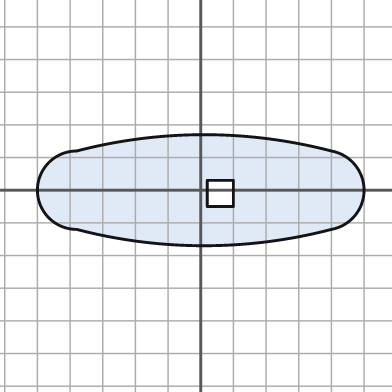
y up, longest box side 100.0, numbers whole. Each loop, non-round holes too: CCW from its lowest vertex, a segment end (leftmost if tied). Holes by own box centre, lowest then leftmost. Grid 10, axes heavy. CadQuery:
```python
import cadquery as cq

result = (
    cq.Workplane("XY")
    .moveTo(-38.0, -12.0)
    .threePointArc((1.0, -17.0), (40.0, -12.0))
    .threePointArc((50.0, 0.0), (40.0, 12.0))
    .threePointArc((1.0, 17.0), (-38.0, 12.0))
    .threePointArc((-50.0, 0.0), (-38.0, -12.0))
    .close()
    .moveTo(2.0, -5.0)
    .lineTo(10.0, -5.0)
    .lineTo(10.0, 3.0)
    .lineTo(2.0, 3.0)
    .close()
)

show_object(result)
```